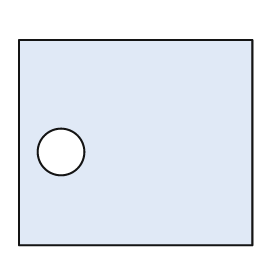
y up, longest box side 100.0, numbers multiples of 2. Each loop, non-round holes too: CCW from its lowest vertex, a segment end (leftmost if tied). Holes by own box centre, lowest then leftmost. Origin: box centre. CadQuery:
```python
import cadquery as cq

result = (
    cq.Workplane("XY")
    .moveTo(-50.0, -44.0)
    .lineTo(50.0, -44.0)
    .lineTo(50.0, 44.0)
    .lineTo(-50.0, 44.0)
    .close()
    .moveTo(-32.0, -4.0)
    .circle(10.0)
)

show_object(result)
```